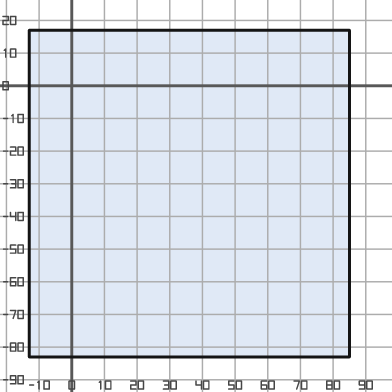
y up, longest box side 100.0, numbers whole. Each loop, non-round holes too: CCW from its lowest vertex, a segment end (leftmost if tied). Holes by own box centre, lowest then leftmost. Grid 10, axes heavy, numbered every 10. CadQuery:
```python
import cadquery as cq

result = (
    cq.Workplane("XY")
    .moveTo(-13.0, -83.0)
    .lineTo(85.0, -83.0)
    .lineTo(85.0, 17.0)
    .lineTo(-13.0, 17.0)
    .close()
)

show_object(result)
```